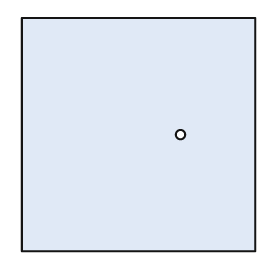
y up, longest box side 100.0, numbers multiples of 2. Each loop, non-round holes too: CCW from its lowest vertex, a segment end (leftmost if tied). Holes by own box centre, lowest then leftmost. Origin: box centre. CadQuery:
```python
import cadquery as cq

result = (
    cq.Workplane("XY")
    .moveTo(-50.0, -50.0)
    .lineTo(50.0, -50.0)
    .lineTo(50.0, 50.0)
    .lineTo(-50.0, 50.0)
    .close()
    .moveTo(18.0, 0.0)
    .circle(2.0)
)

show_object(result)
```